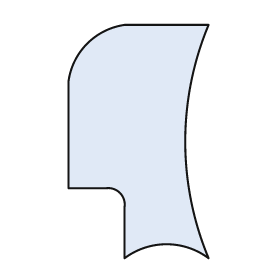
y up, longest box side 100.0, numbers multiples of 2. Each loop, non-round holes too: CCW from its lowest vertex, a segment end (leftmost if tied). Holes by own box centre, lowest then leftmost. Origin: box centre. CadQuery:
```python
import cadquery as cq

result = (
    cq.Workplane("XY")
    .moveTo(-6.0, -50.0)
    .threePointArc((12.0, -44.0), (30.0, -50.0))
    .threePointArc((20.0, 0.0), (30.0, 50.0))
    .lineTo(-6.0, 50.0)
    .threePointArc((-22.0, 42.0), (-30.0, 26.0))
    .lineTo(-30.0, -20.0)
    .lineTo(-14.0, -20.0)
    .threePointArc((-8.0, -22.0), (-6.0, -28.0))
    .close()
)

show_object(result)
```